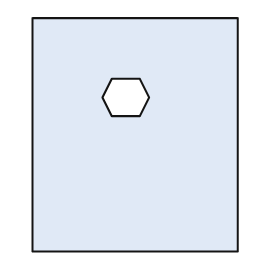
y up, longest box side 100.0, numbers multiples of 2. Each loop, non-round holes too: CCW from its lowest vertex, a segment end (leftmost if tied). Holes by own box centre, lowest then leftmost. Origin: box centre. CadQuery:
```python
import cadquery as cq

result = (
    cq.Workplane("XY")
    .moveTo(-44.0, -50.0)
    .lineTo(44.0, -50.0)
    .lineTo(44.0, 50.0)
    .lineTo(-44.0, 50.0)
    .close()
    .moveTo(-10.0, 8.0)
    .lineTo(2.0, 8.0)
    .lineTo(6.0, 16.0)
    .lineTo(2.0, 24.0)
    .lineTo(-10.0, 24.0)
    .lineTo(-14.0, 16.0)
    .close()
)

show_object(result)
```